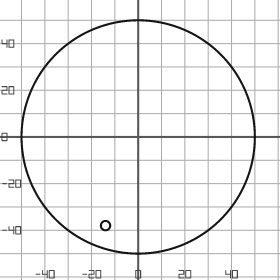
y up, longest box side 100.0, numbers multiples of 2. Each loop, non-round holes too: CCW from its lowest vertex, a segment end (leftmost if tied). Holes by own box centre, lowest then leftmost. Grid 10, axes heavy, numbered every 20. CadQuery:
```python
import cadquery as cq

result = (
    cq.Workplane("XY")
    .moveTo(0.0, 0.0)
    .circle(50.0)
    .moveTo(-14.0, -38.0)
    .circle(2.0)
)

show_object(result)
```